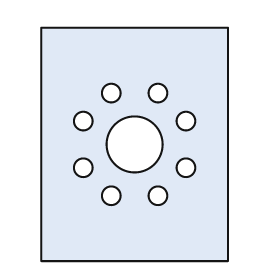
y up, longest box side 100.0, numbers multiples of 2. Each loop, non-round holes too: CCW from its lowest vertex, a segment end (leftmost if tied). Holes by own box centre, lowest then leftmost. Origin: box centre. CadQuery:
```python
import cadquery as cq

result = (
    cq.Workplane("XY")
    .moveTo(-40.0, -50.0)
    .lineTo(40.0, -50.0)
    .lineTo(40.0, 50.0)
    .lineTo(-40.0, 50.0)
    .close()
    .moveTo(-10.0, -22.0)
    .circle(4.0)
    .moveTo(10.0, -22.0)
    .circle(4.0)
    .moveTo(-22.0, -10.0)
    .circle(4.0)
    .moveTo(22.0, -10.0)
    .circle(4.0)
    .moveTo(0.0, 0.0)
    .circle(12.0)
    .moveTo(-22.0, 10.0)
    .circle(4.0)
    .moveTo(22.0, 10.0)
    .circle(4.0)
    .moveTo(-10.0, 22.0)
    .circle(4.0)
    .moveTo(10.0, 22.0)
    .circle(4.0)
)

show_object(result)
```